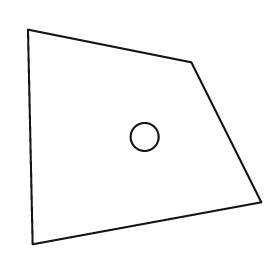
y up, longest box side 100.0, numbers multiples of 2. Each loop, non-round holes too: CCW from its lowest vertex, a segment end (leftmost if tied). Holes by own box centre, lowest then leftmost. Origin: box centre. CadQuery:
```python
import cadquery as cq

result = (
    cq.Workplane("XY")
    .moveTo(-48.0, -46.0)
    .lineTo(50.0, -28.0)
    .lineTo(20.0, 32.0)
    .lineTo(-50.0, 46.0)
    .close()
    .moveTo(0.0, 0.0)
    .circle(6.0)
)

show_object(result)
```